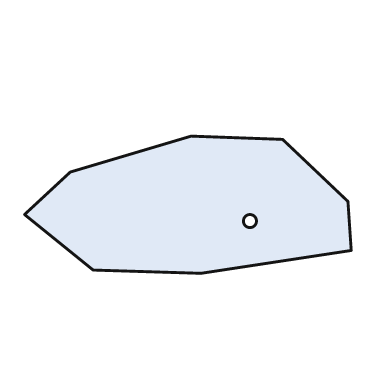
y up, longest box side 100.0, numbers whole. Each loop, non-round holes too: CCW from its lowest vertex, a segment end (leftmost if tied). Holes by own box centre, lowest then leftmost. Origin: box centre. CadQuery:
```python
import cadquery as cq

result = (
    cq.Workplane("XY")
    .moveTo(4.0, -21.0)
    .lineTo(50.0, -14.0)
    .lineTo(49.0, 1.0)
    .lineTo(29.0, 20.0)
    .lineTo(1.0, 21.0)
    .lineTo(-36.0, 10.0)
    .lineTo(-50.0, -3.0)
    .lineTo(-29.0, -20.0)
    .close()
    .moveTo(19.0, -5.0)
    .circle(2.0)
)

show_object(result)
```